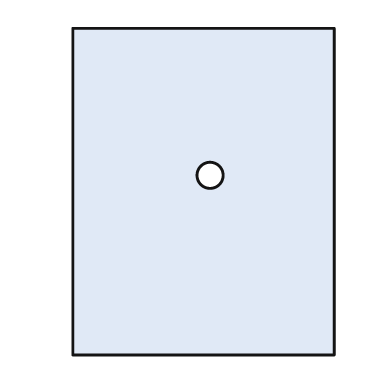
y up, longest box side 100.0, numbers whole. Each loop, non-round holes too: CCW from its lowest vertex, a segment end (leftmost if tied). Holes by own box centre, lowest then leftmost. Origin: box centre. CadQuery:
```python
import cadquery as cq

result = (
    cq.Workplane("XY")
    .moveTo(-40.0, -50.0)
    .lineTo(40.0, -50.0)
    .lineTo(40.0, 50.0)
    .lineTo(-40.0, 50.0)
    .close()
    .moveTo(2.0, 5.0)
    .circle(4.0)
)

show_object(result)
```